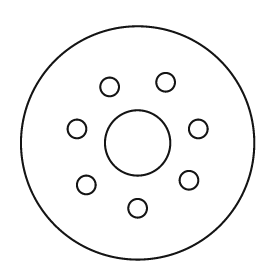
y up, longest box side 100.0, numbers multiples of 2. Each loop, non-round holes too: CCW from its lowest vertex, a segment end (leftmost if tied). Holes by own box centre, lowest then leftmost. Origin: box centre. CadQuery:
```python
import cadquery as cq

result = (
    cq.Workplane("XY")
    .moveTo(0.0, 0.0)
    .circle(50.0)
    .moveTo(0.0, -28.0)
    .circle(4.0)
    .moveTo(-22.0, -18.0)
    .circle(4.0)
    .moveTo(22.0, -16.0)
    .circle(4.0)
    .moveTo(0.0, 0.0)
    .circle(14.0)
    .moveTo(-26.0, 6.0)
    .circle(4.0)
    .moveTo(26.0, 6.0)
    .circle(4.0)
    .moveTo(-12.0, 24.0)
    .circle(4.0)
    .moveTo(12.0, 26.0)
    .circle(4.0)
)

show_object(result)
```